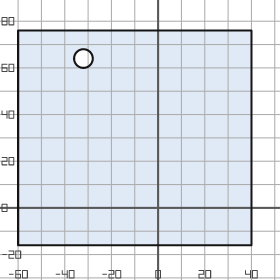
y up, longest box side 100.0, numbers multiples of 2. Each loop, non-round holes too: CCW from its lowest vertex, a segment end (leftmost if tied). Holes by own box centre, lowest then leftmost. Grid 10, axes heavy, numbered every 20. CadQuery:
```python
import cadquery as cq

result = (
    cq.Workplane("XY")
    .moveTo(-60.0, -16.0)
    .lineTo(40.0, -16.0)
    .lineTo(40.0, 76.0)
    .lineTo(-60.0, 76.0)
    .close()
    .moveTo(-32.0, 64.0)
    .circle(4.0)
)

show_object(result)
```